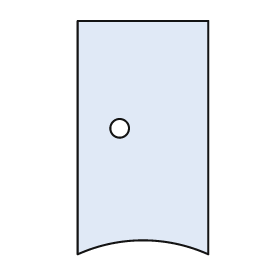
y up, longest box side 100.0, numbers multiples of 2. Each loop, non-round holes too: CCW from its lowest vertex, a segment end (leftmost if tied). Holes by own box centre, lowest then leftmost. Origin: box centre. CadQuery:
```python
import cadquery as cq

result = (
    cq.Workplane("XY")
    .moveTo(-28.0, -50.0)
    .threePointArc((0.0, -44.0), (28.0, -50.0))
    .lineTo(28.0, 50.0)
    .lineTo(-28.0, 50.0)
    .close()
    .moveTo(-10.0, 4.0)
    .circle(4.0)
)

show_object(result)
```